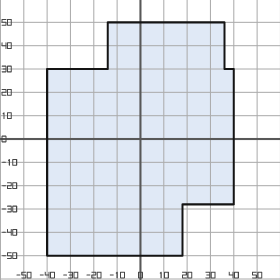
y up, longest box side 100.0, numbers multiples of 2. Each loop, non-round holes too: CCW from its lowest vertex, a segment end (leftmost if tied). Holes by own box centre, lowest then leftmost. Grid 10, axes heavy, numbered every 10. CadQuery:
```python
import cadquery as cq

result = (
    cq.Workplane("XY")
    .moveTo(-40.0, -50.0)
    .lineTo(18.0, -50.0)
    .lineTo(18.0, -28.0)
    .lineTo(40.0, -28.0)
    .lineTo(40.0, 30.0)
    .lineTo(36.0, 30.0)
    .lineTo(36.0, 50.0)
    .lineTo(-14.0, 50.0)
    .lineTo(-14.0, 30.0)
    .lineTo(-40.0, 30.0)
    .close()
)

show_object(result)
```